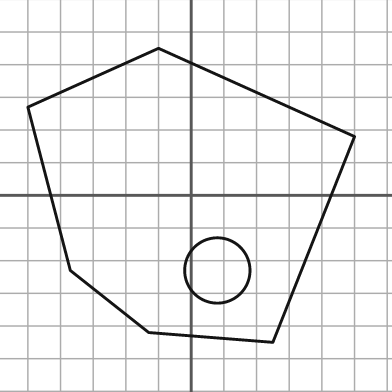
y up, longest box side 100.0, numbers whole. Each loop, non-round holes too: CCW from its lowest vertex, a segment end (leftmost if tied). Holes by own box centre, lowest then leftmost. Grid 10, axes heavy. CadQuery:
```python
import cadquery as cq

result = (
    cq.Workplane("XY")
    .moveTo(25.0, -45.0)
    .lineTo(50.0, 18.0)
    .lineTo(-10.0, 45.0)
    .lineTo(-50.0, 27.0)
    .lineTo(-37.0, -23.0)
    .lineTo(-13.0, -42.0)
    .close()
    .moveTo(8.0, -23.0)
    .circle(10.0)
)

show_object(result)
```